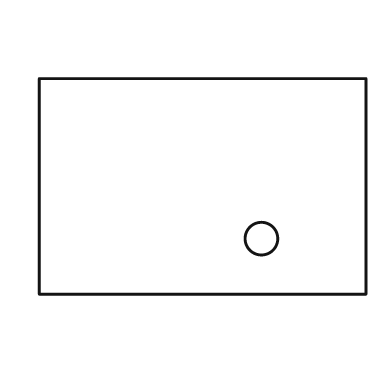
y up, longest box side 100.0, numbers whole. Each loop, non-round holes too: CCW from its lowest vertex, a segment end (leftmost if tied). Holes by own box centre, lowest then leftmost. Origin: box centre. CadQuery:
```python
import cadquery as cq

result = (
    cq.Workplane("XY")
    .moveTo(-50.0, -33.0)
    .lineTo(50.0, -33.0)
    .lineTo(50.0, 33.0)
    .lineTo(-50.0, 33.0)
    .close()
    .moveTo(18.0, -16.0)
    .circle(5.0)
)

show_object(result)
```